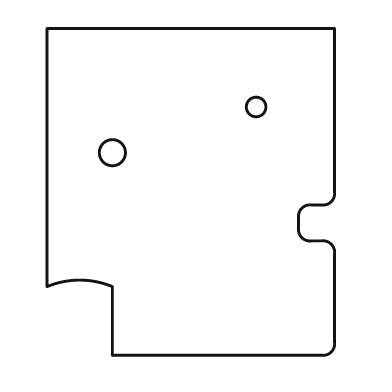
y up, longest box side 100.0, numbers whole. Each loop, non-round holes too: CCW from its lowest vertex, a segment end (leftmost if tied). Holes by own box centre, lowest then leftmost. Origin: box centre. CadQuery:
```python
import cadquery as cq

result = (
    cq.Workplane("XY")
    .moveTo(-24.0, -50.0)
    .lineTo(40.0, -50.0)
    .threePointArc((43.0, -49.0), (44.0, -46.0))
    .lineTo(44.0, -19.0)
    .threePointArc((43.0, -16.0), (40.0, -15.0))
    .lineTo(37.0, -15.0)
    .threePointArc((34.0, -14.0), (33.0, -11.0))
    .lineTo(33.0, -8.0)
    .threePointArc((34.0, -5.0), (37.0, -4.0))
    .lineTo(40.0, -4.0)
    .threePointArc((43.0, -3.0), (44.0, 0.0))
    .lineTo(44.0, 50.0)
    .lineTo(-44.0, 50.0)
    .lineTo(-44.0, -29.0)
    .threePointArc((-34.0, -27.0), (-24.0, -29.0))
    .close()
    .moveTo(-24.0, 12.0)
    .circle(4.0)
    .moveTo(20.0, 26.0)
    .circle(3.0)
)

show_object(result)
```